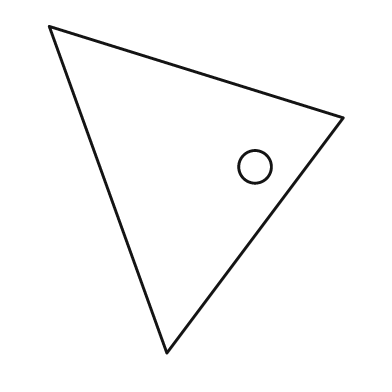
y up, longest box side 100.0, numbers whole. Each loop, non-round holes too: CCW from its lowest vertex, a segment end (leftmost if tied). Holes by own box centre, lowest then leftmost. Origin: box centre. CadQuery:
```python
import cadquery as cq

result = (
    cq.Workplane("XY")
    .moveTo(-9.0, -50.0)
    .lineTo(45.0, 22.0)
    .lineTo(-45.0, 50.0)
    .close()
    .moveTo(18.0, 7.0)
    .circle(5.0)
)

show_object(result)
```